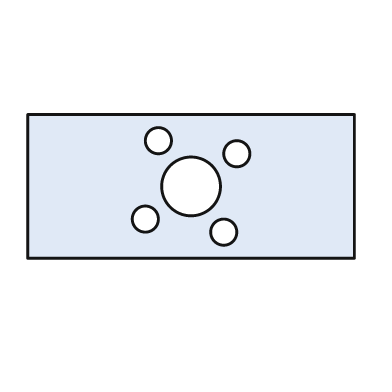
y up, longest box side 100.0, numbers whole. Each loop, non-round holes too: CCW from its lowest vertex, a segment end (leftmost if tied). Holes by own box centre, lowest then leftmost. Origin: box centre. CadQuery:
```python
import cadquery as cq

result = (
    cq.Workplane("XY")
    .moveTo(-50.0, -22.0)
    .lineTo(50.0, -22.0)
    .lineTo(50.0, 22.0)
    .lineTo(-50.0, 22.0)
    .close()
    .moveTo(10.0, -14.0)
    .circle(4.0)
    .moveTo(-14.0, -10.0)
    .circle(4.0)
    .moveTo(0.0, 0.0)
    .circle(9.0)
    .moveTo(14.0, 10.0)
    .circle(4.0)
    .moveTo(-10.0, 14.0)
    .circle(4.0)
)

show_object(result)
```